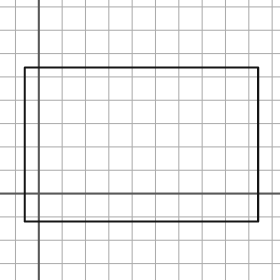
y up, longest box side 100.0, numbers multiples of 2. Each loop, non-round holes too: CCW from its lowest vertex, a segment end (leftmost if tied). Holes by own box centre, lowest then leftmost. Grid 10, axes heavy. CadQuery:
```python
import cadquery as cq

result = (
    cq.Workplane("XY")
    .moveTo(-6.0, -12.0)
    .lineTo(94.0, -12.0)
    .lineTo(94.0, 54.0)
    .lineTo(-6.0, 54.0)
    .close()
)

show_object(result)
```